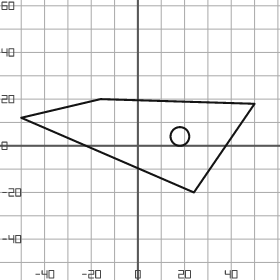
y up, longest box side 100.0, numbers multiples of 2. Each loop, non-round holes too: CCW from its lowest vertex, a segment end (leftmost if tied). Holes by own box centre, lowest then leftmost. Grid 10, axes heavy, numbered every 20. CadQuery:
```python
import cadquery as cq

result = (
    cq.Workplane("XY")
    .moveTo(24.0, -20.0)
    .lineTo(50.0, 18.0)
    .lineTo(-16.0, 20.0)
    .lineTo(-50.0, 12.0)
    .close()
    .moveTo(18.0, 4.0)
    .circle(4.0)
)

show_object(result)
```